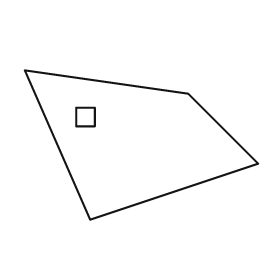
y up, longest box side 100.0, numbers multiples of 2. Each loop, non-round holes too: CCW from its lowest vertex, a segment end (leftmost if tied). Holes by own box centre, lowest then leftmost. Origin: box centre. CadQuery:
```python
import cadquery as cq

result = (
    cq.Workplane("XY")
    .moveTo(-22.0, -32.0)
    .lineTo(50.0, -8.0)
    .lineTo(20.0, 22.0)
    .lineTo(-50.0, 32.0)
    .close()
    .moveTo(-28.0, 8.0)
    .lineTo(-20.0, 8.0)
    .lineTo(-20.0, 16.0)
    .lineTo(-28.0, 16.0)
    .close()
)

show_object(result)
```